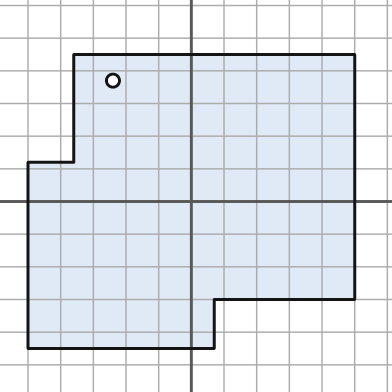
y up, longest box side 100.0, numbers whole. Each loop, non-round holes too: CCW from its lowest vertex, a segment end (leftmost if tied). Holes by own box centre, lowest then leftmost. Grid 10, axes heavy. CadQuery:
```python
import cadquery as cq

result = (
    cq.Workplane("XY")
    .moveTo(-50.0, -45.0)
    .lineTo(7.0, -45.0)
    .lineTo(7.0, -30.0)
    .lineTo(50.0, -30.0)
    .lineTo(50.0, 45.0)
    .lineTo(-36.0, 45.0)
    .lineTo(-36.0, 12.0)
    .lineTo(-50.0, 12.0)
    .close()
    .moveTo(-24.0, 37.0)
    .circle(2.0)
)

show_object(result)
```